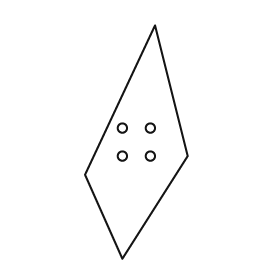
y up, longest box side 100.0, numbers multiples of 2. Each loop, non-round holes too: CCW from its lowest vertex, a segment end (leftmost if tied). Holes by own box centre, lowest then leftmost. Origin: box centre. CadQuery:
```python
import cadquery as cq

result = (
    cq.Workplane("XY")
    .moveTo(-6.0, -50.0)
    .lineTo(22.0, -6.0)
    .lineTo(8.0, 50.0)
    .lineTo(-22.0, -14.0)
    .close()
    .moveTo(-6.0, -6.0)
    .circle(2.0)
    .moveTo(6.0, -6.0)
    .circle(2.0)
    .moveTo(-6.0, 6.0)
    .circle(2.0)
    .moveTo(6.0, 6.0)
    .circle(2.0)
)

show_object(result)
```